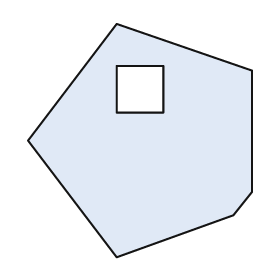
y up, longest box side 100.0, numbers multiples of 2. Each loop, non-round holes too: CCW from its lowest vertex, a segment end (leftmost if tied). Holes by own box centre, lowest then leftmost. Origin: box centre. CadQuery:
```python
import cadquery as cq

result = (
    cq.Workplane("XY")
    .moveTo(-10.0, -50.0)
    .lineTo(40.0, -32.0)
    .lineTo(48.0, -22.0)
    .lineTo(48.0, 30.0)
    .lineTo(-10.0, 50.0)
    .lineTo(-48.0, 0.0)
    .close()
    .moveTo(-10.0, 12.0)
    .lineTo(10.0, 12.0)
    .lineTo(10.0, 32.0)
    .lineTo(-10.0, 32.0)
    .close()
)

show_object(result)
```